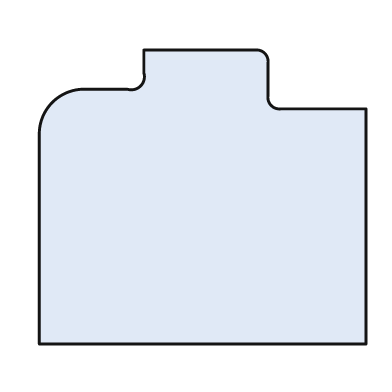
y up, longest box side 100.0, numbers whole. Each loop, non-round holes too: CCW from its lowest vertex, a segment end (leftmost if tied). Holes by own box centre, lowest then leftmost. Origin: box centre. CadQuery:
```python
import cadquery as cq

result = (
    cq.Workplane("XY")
    .moveTo(-50.0, -45.0)
    .lineTo(50.0, -45.0)
    .lineTo(50.0, 27.0)
    .lineTo(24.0, 27.0)
    .threePointArc((21.0, 28.0), (20.0, 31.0))
    .lineTo(20.0, 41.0)
    .threePointArc((19.0, 44.0), (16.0, 45.0))
    .lineTo(-18.0, 45.0)
    .lineTo(-18.0, 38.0)
    .threePointArc((-19.0, 34.0), (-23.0, 33.0))
    .lineTo(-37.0, 33.0)
    .threePointArc((-46.0, 29.0), (-50.0, 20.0))
    .close()
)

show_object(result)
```